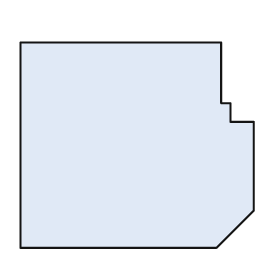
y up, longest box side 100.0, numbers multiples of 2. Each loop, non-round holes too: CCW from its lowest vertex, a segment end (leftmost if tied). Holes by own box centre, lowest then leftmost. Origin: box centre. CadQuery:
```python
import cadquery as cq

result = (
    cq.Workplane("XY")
    .moveTo(-50.0, -44.0)
    .lineTo(34.0, -44.0)
    .lineTo(50.0, -28.0)
    .lineTo(50.0, 10.0)
    .lineTo(40.0, 10.0)
    .lineTo(40.0, 18.0)
    .lineTo(36.0, 18.0)
    .lineTo(36.0, 44.0)
    .lineTo(-50.0, 44.0)
    .close()
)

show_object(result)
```